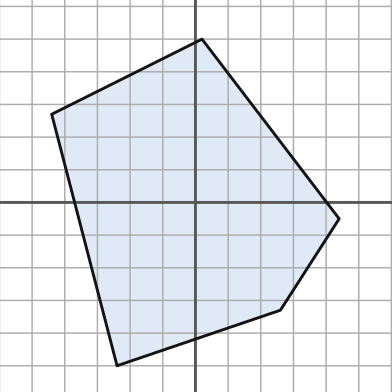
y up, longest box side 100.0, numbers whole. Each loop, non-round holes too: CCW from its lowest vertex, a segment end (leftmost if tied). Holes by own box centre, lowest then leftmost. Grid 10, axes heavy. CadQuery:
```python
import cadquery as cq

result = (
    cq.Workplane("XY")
    .moveTo(-24.0, -50.0)
    .lineTo(26.0, -33.0)
    .lineTo(44.0, -5.0)
    .lineTo(2.0, 50.0)
    .lineTo(-44.0, 27.0)
    .close()
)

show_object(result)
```